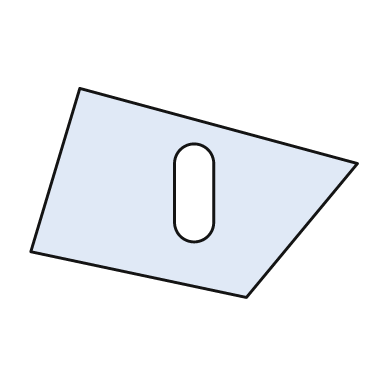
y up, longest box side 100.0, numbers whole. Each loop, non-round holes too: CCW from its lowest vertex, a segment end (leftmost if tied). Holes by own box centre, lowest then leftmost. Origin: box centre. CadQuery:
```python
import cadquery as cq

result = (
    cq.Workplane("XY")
    .moveTo(16.0, -32.0)
    .lineTo(50.0, 9.0)
    .lineTo(-35.0, 32.0)
    .lineTo(-50.0, -18.0)
    .close()
    .moveTo(-6.0, -9.0)
    .threePointArc((0.0, -15.0), (6.0, -9.0))
    .lineTo(6.0, 9.0)
    .threePointArc((0.0, 15.0), (-6.0, 9.0))
    .close()
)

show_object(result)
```